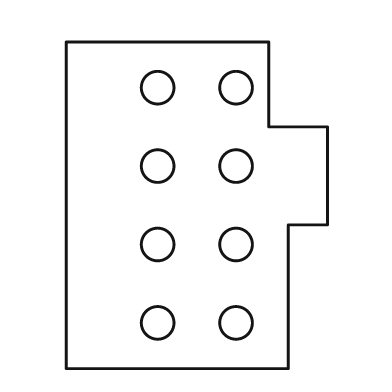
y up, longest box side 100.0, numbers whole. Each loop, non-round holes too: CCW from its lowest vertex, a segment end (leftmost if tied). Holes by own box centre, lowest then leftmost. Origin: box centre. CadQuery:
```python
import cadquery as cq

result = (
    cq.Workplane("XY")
    .moveTo(-40.0, -50.0)
    .lineTo(28.0, -50.0)
    .lineTo(28.0, -6.0)
    .lineTo(40.0, -6.0)
    .lineTo(40.0, 24.0)
    .lineTo(22.0, 24.0)
    .lineTo(22.0, 50.0)
    .lineTo(-40.0, 50.0)
    .close()
    .moveTo(-12.0, -36.0)
    .circle(5.0)
    .moveTo(12.0, -36.0)
    .circle(5.0)
    .moveTo(-12.0, -12.0)
    .circle(5.0)
    .moveTo(12.0, -12.0)
    .circle(5.0)
    .moveTo(-12.0, 12.0)
    .circle(5.0)
    .moveTo(12.0, 12.0)
    .circle(5.0)
    .moveTo(-12.0, 36.0)
    .circle(5.0)
    .moveTo(12.0, 36.0)
    .circle(5.0)
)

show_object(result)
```